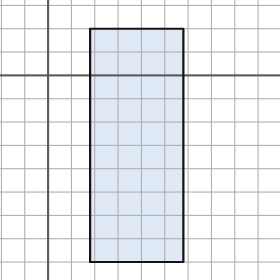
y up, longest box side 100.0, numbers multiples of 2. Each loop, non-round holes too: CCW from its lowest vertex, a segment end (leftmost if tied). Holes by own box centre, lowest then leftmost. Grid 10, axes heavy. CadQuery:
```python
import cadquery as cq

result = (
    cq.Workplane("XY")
    .moveTo(18.0, -80.0)
    .lineTo(58.0, -80.0)
    .lineTo(58.0, 20.0)
    .lineTo(18.0, 20.0)
    .close()
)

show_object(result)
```